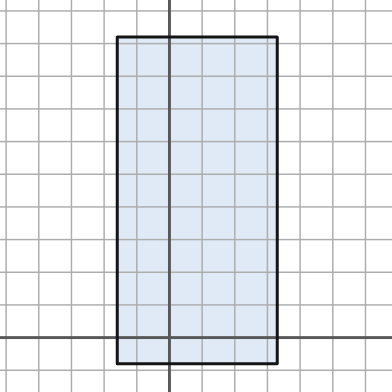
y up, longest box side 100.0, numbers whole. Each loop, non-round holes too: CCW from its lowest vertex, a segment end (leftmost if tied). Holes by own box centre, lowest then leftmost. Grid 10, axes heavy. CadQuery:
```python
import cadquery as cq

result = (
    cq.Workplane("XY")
    .moveTo(-16.0, -8.0)
    .lineTo(33.0, -8.0)
    .lineTo(33.0, 92.0)
    .lineTo(-16.0, 92.0)
    .close()
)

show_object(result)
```